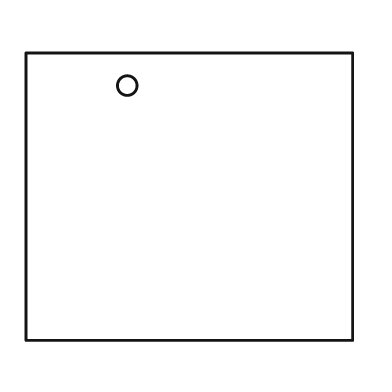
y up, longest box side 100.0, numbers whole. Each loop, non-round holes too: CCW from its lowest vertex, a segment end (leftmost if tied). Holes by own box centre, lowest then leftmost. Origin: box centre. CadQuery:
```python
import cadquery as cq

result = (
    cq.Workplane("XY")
    .moveTo(-50.0, -44.0)
    .lineTo(50.0, -44.0)
    .lineTo(50.0, 44.0)
    .lineTo(-50.0, 44.0)
    .close()
    .moveTo(-19.0, 34.0)
    .circle(3.0)
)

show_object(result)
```